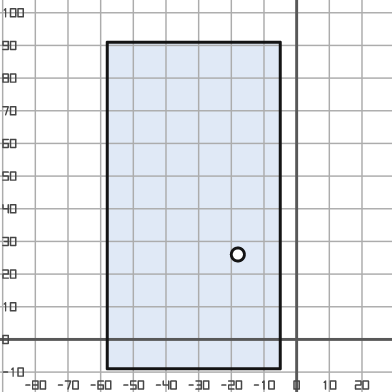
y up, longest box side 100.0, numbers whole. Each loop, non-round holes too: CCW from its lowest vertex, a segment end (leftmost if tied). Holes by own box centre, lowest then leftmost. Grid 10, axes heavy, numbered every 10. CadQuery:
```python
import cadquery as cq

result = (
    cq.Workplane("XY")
    .moveTo(-58.0, -9.0)
    .lineTo(-5.0, -9.0)
    .lineTo(-5.0, 91.0)
    .lineTo(-58.0, 91.0)
    .close()
    .moveTo(-18.0, 26.0)
    .circle(2.0)
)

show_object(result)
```